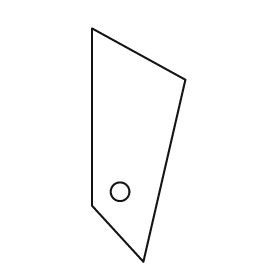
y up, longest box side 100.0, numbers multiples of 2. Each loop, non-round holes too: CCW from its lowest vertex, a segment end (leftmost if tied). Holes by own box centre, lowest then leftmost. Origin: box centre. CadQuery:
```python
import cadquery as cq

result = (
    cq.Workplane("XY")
    .moveTo(2.0, -50.0)
    .lineTo(20.0, 28.0)
    .lineTo(-20.0, 50.0)
    .lineTo(-20.0, -26.0)
    .close()
    .moveTo(-8.0, -20.0)
    .circle(4.0)
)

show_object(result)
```